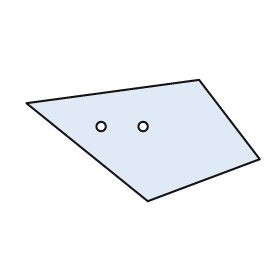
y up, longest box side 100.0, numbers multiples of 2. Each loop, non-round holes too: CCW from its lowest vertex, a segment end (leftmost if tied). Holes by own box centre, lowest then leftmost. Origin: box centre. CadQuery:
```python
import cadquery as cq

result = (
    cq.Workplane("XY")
    .moveTo(2.0, -26.0)
    .lineTo(50.0, -8.0)
    .lineTo(24.0, 26.0)
    .lineTo(-50.0, 16.0)
    .close()
    .moveTo(-18.0, 6.0)
    .circle(2.0)
    .moveTo(0.0, 6.0)
    .circle(2.0)
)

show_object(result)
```